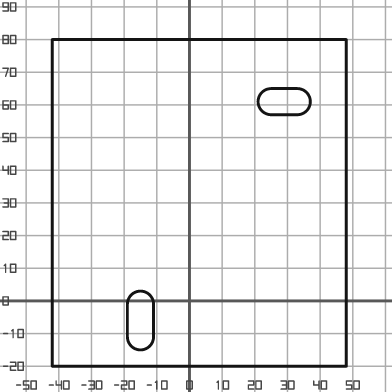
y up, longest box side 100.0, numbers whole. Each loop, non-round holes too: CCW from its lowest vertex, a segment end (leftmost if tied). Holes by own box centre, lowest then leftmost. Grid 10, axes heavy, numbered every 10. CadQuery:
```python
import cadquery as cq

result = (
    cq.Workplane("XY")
    .moveTo(-42.0, -20.0)
    .lineTo(48.0, -20.0)
    .lineTo(48.0, 80.0)
    .lineTo(-42.0, 80.0)
    .close()
    .moveTo(-19.0, -11.0)
    .threePointArc((-15.0, -15.0), (-11.0, -11.0))
    .lineTo(-11.0, -1.0)
    .threePointArc((-15.0, 3.0), (-19.0, -1.0))
    .close()
    .moveTo(25.0, 57.0)
    .lineTo(33.0, 57.0)
    .threePointArc((37.0, 61.0), (33.0, 65.0))
    .lineTo(25.0, 65.0)
    .threePointArc((21.0, 61.0), (25.0, 57.0))
    .close()
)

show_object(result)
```